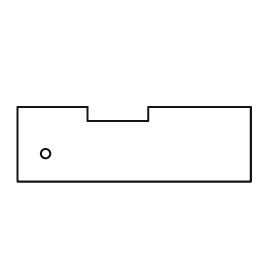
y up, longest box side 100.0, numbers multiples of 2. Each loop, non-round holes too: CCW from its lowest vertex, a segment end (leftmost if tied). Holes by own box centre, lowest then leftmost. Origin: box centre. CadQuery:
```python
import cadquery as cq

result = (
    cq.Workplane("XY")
    .moveTo(-50.0, -16.0)
    .lineTo(50.0, -16.0)
    .lineTo(50.0, 16.0)
    .lineTo(6.0, 16.0)
    .lineTo(6.0, 10.0)
    .lineTo(-20.0, 10.0)
    .lineTo(-20.0, 16.0)
    .lineTo(-50.0, 16.0)
    .close()
    .moveTo(-38.0, -4.0)
    .circle(2.0)
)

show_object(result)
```